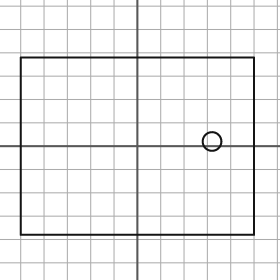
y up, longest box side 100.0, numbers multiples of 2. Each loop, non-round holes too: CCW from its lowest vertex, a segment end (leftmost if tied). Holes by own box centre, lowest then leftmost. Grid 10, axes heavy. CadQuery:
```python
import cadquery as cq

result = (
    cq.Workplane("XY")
    .moveTo(-50.0, -38.0)
    .lineTo(50.0, -38.0)
    .lineTo(50.0, 38.0)
    .lineTo(-50.0, 38.0)
    .close()
    .moveTo(32.0, 2.0)
    .circle(4.0)
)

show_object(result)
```